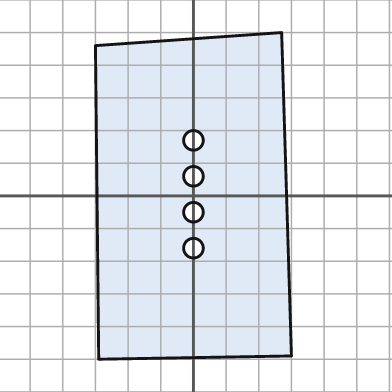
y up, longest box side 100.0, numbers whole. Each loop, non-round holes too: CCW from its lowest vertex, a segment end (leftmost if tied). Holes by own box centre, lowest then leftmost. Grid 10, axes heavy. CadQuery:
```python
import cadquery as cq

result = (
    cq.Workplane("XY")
    .moveTo(-29.0, -50.0)
    .lineTo(30.0, -49.0)
    .lineTo(27.0, 50.0)
    .lineTo(-30.0, 46.0)
    .close()
    .moveTo(0.0, -16.0)
    .circle(3.0)
    .moveTo(0.0, -5.0)
    .circle(3.0)
    .moveTo(0.0, 6.0)
    .circle(3.0)
    .moveTo(0.0, 17.0)
    .circle(3.0)
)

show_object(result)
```